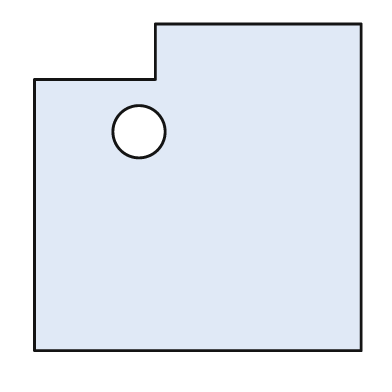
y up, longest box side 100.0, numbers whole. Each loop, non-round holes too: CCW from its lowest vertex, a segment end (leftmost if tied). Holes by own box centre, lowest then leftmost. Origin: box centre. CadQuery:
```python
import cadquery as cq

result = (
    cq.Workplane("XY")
    .moveTo(-50.0, -50.0)
    .lineTo(50.0, -50.0)
    .lineTo(50.0, 50.0)
    .lineTo(-13.0, 50.0)
    .lineTo(-13.0, 33.0)
    .lineTo(-50.0, 33.0)
    .close()
    .moveTo(-18.0, 17.0)
    .circle(8.0)
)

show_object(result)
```